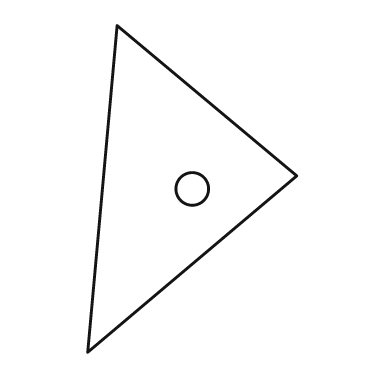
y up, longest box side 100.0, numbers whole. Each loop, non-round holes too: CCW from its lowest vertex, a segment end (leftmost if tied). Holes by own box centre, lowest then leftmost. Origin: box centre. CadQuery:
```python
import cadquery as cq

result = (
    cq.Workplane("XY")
    .moveTo(-32.0, -50.0)
    .lineTo(32.0, 4.0)
    .lineTo(-23.0, 50.0)
    .close()
    .moveTo(0.0, 0.0)
    .circle(5.0)
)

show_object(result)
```